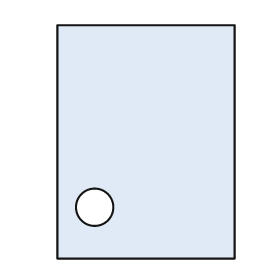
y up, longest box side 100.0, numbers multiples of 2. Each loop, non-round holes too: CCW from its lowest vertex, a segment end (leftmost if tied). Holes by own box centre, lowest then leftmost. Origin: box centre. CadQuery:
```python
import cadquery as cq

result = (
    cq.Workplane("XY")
    .moveTo(-38.0, -50.0)
    .lineTo(38.0, -50.0)
    .lineTo(38.0, 50.0)
    .lineTo(-38.0, 50.0)
    .close()
    .moveTo(-22.0, -28.0)
    .circle(8.0)
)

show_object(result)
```